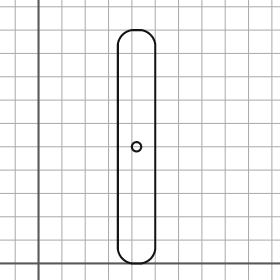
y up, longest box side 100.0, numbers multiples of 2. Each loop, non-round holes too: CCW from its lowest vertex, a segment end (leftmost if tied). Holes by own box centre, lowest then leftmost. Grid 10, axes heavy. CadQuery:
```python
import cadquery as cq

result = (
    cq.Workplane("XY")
    .moveTo(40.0, 0.0)
    .lineTo(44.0, 0.0)
    .threePointArc((48.0, 2.0), (50.0, 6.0))
    .lineTo(50.0, 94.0)
    .threePointArc((48.0, 98.0), (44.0, 100.0))
    .lineTo(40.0, 100.0)
    .threePointArc((36.0, 98.0), (34.0, 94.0))
    .lineTo(34.0, 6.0)
    .threePointArc((36.0, 2.0), (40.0, 0.0))
    .close()
    .moveTo(42.0, 50.0)
    .circle(2.0)
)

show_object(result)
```